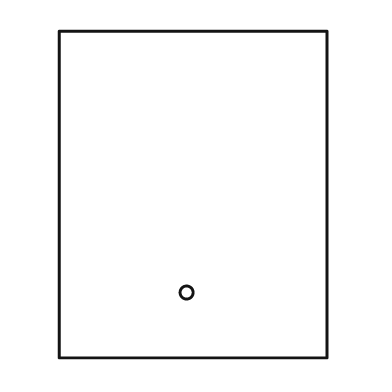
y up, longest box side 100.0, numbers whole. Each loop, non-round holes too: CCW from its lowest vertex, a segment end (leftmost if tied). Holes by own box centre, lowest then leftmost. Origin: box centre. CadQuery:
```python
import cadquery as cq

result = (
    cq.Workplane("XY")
    .moveTo(-41.0, -50.0)
    .lineTo(41.0, -50.0)
    .lineTo(41.0, 50.0)
    .lineTo(-41.0, 50.0)
    .close()
    .moveTo(-2.0, -30.0)
    .circle(2.0)
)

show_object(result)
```